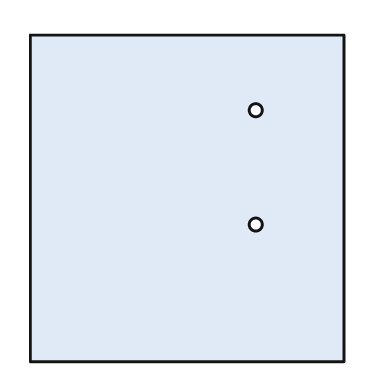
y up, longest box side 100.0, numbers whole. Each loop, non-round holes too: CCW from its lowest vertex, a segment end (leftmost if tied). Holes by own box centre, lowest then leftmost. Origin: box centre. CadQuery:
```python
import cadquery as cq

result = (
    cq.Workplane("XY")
    .moveTo(-48.0, -50.0)
    .lineTo(48.0, -50.0)
    .lineTo(48.0, 50.0)
    .lineTo(-48.0, 50.0)
    .close()
    .moveTo(21.0, -8.0)
    .circle(2.0)
    .moveTo(21.0, 27.0)
    .circle(2.0)
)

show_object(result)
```